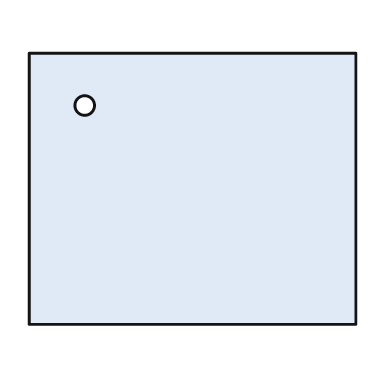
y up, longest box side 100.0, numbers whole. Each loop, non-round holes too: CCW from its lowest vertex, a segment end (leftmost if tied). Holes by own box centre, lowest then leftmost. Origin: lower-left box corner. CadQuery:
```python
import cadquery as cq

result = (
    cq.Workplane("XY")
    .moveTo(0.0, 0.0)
    .lineTo(100.0, 0.0)
    .lineTo(100.0, 83.0)
    .lineTo(0.0, 83.0)
    .close()
    .moveTo(17.0, 67.0)
    .circle(3.0)
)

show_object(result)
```